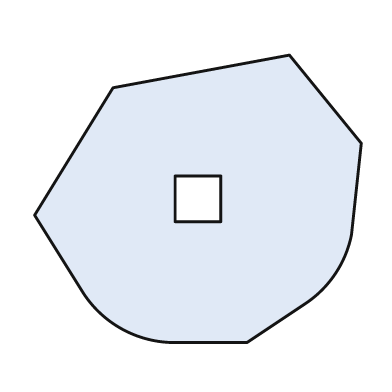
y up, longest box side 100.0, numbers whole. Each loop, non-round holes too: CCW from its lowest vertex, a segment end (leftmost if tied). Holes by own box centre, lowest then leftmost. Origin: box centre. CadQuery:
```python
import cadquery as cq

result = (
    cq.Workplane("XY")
    .moveTo(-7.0, -44.0)
    .lineTo(15.0, -44.0)
    .lineTo(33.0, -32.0)
    .threePointArc((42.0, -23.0), (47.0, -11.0))
    .lineTo(50.0, 17.0)
    .lineTo(28.0, 44.0)
    .lineTo(-26.0, 34.0)
    .lineTo(-50.0, -5.0)
    .lineTo(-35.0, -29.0)
    .threePointArc((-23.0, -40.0), (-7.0, -44.0))
    .close()
    .moveTo(-7.0, -7.0)
    .lineTo(7.0, -7.0)
    .lineTo(7.0, 7.0)
    .lineTo(-7.0, 7.0)
    .close()
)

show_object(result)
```